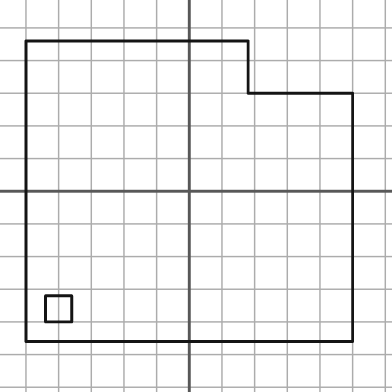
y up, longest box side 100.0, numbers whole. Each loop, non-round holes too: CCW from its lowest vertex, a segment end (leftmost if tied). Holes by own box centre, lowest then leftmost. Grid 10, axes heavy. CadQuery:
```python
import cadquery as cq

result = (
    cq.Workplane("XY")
    .moveTo(-50.0, -46.0)
    .lineTo(50.0, -46.0)
    .lineTo(50.0, 30.0)
    .lineTo(18.0, 30.0)
    .lineTo(18.0, 46.0)
    .lineTo(-50.0, 46.0)
    .close()
    .moveTo(-44.0, -40.0)
    .lineTo(-36.0, -40.0)
    .lineTo(-36.0, -32.0)
    .lineTo(-44.0, -32.0)
    .close()
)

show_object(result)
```